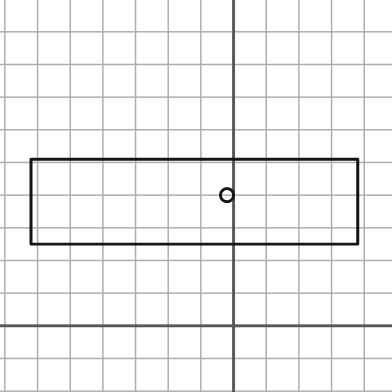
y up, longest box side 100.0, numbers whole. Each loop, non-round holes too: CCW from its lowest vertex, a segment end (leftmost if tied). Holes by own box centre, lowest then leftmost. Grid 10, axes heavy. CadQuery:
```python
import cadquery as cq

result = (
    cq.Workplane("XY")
    .moveTo(-62.0, 25.0)
    .lineTo(38.0, 25.0)
    .lineTo(38.0, 51.0)
    .lineTo(-62.0, 51.0)
    .close()
    .moveTo(-2.0, 40.0)
    .circle(2.0)
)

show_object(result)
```